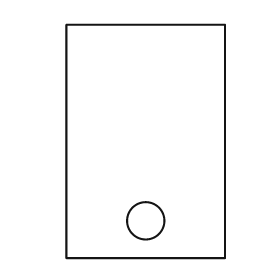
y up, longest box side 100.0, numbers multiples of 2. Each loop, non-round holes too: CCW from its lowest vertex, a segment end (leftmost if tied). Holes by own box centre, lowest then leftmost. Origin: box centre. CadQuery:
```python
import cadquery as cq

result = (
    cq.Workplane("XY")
    .moveTo(-34.0, -50.0)
    .lineTo(34.0, -50.0)
    .lineTo(34.0, 50.0)
    .lineTo(-34.0, 50.0)
    .close()
    .moveTo(0.0, -34.0)
    .circle(8.0)
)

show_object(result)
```